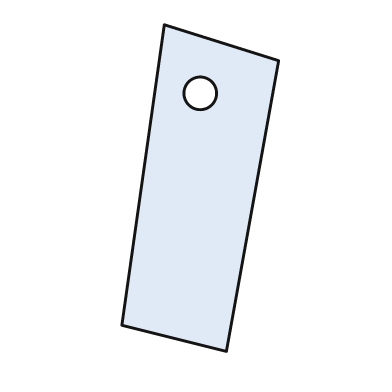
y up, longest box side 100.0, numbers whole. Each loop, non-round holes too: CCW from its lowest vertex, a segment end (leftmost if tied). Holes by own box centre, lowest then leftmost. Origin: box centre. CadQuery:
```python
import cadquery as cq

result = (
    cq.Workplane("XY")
    .moveTo(8.0, -50.0)
    .lineTo(24.0, 39.0)
    .lineTo(-11.0, 50.0)
    .lineTo(-24.0, -42.0)
    .close()
    .moveTo(0.0, 29.0)
    .circle(5.0)
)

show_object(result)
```